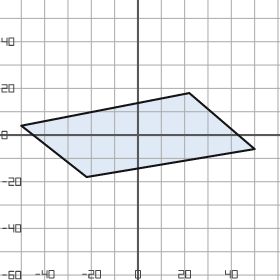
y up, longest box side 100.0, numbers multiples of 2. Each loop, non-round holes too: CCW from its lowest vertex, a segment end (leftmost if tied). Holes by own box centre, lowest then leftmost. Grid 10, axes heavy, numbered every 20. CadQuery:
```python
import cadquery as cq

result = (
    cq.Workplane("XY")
    .moveTo(-22.0, -18.0)
    .lineTo(50.0, -6.0)
    .lineTo(22.0, 18.0)
    .lineTo(-50.0, 4.0)
    .close()
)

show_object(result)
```